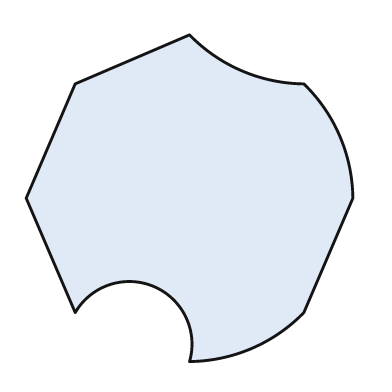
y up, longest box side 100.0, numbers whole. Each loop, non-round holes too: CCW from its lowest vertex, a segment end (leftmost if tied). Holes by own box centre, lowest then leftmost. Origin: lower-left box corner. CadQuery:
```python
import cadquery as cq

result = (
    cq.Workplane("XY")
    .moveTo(50.0, 0.0)
    .threePointArc((69.0, 4.0), (85.0, 15.0))
    .lineTo(100.0, 50.0)
    .threePointArc((96.0, 69.0), (85.0, 85.0))
    .threePointArc((66.0, 89.0), (50.0, 100.0))
    .lineTo(15.0, 85.0)
    .lineTo(0.0, 50.0)
    .lineTo(15.0, 15.0)
    .threePointArc((39.0, 23.0), (50.0, 0.0))
    .close()
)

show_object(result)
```